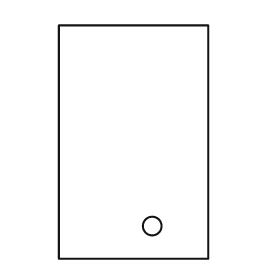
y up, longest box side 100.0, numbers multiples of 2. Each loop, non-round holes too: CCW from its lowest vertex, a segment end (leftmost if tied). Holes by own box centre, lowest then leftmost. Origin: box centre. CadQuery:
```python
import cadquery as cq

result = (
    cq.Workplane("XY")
    .moveTo(-32.0, -50.0)
    .lineTo(32.0, -50.0)
    .lineTo(32.0, 50.0)
    .lineTo(-32.0, 50.0)
    .close()
    .moveTo(8.0, -36.0)
    .circle(4.0)
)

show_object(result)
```